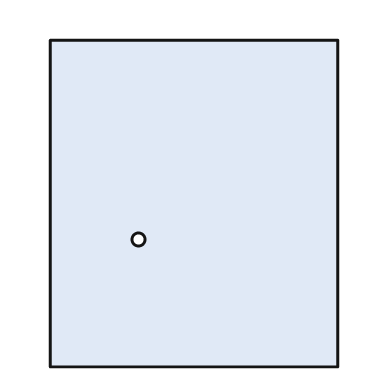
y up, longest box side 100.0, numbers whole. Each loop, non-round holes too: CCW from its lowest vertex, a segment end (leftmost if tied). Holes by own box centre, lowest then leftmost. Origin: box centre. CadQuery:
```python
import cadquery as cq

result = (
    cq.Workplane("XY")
    .moveTo(-44.0, -50.0)
    .lineTo(44.0, -50.0)
    .lineTo(44.0, 50.0)
    .lineTo(-44.0, 50.0)
    .close()
    .moveTo(-17.0, -11.0)
    .circle(2.0)
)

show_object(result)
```